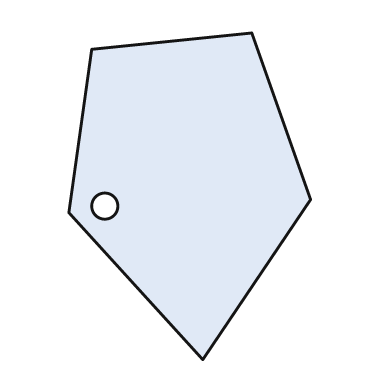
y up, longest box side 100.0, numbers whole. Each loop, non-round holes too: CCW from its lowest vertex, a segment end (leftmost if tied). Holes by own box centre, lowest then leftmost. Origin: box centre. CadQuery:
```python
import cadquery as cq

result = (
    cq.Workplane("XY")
    .moveTo(4.0, -50.0)
    .lineTo(37.0, -1.0)
    .lineTo(19.0, 50.0)
    .lineTo(-30.0, 45.0)
    .lineTo(-37.0, -5.0)
    .close()
    .moveTo(-26.0, -3.0)
    .circle(4.0)
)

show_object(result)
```